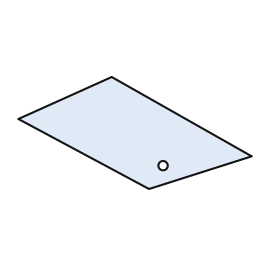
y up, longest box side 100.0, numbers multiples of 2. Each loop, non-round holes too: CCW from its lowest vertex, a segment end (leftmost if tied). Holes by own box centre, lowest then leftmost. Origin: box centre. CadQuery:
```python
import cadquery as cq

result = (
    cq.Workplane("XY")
    .moveTo(6.0, -24.0)
    .lineTo(50.0, -10.0)
    .lineTo(-10.0, 24.0)
    .lineTo(-50.0, 6.0)
    .close()
    .moveTo(12.0, -14.0)
    .circle(2.0)
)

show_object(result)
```